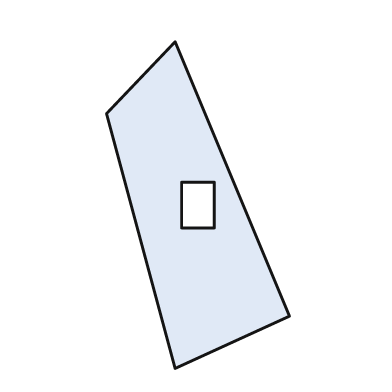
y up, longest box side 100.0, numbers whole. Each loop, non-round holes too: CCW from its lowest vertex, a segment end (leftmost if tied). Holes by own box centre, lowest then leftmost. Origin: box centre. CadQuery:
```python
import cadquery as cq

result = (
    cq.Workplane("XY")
    .moveTo(-7.0, -50.0)
    .lineTo(28.0, -34.0)
    .lineTo(-7.0, 50.0)
    .lineTo(-28.0, 28.0)
    .close()
    .moveTo(-5.0, -7.0)
    .lineTo(5.0, -7.0)
    .lineTo(5.0, 7.0)
    .lineTo(-5.0, 7.0)
    .close()
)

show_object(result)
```